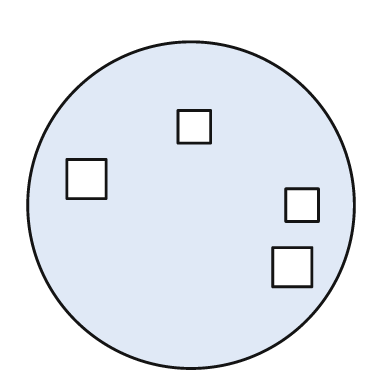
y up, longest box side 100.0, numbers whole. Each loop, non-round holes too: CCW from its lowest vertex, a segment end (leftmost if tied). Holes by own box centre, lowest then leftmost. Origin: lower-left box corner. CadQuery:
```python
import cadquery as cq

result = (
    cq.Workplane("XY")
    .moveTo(50.0, 50.0)
    .circle(50.0)
    .moveTo(75.0, 25.0)
    .lineTo(87.0, 25.0)
    .lineTo(87.0, 37.0)
    .lineTo(75.0, 37.0)
    .close()
    .moveTo(79.0, 45.0)
    .lineTo(89.0, 45.0)
    .lineTo(89.0, 55.0)
    .lineTo(79.0, 55.0)
    .close()
    .moveTo(12.0, 52.0)
    .lineTo(24.0, 52.0)
    .lineTo(24.0, 64.0)
    .lineTo(12.0, 64.0)
    .close()
    .moveTo(46.0, 69.0)
    .lineTo(56.0, 69.0)
    .lineTo(56.0, 79.0)
    .lineTo(46.0, 79.0)
    .close()
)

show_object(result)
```